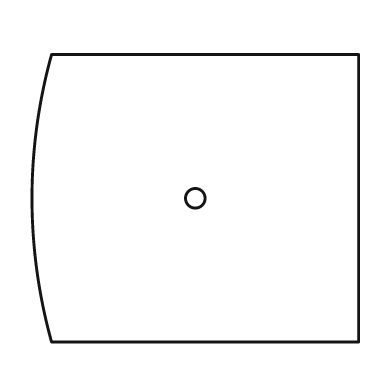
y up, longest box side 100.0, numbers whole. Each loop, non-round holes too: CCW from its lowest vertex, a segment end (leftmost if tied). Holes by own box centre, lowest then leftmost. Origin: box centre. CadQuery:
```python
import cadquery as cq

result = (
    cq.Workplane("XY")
    .moveTo(-44.0, -44.0)
    .lineTo(50.0, -44.0)
    .lineTo(50.0, 44.0)
    .lineTo(-44.0, 44.0)
    .threePointArc((-50.0, 0.0), (-44.0, -44.0))
    .close()
    .moveTo(0.0, 0.0)
    .circle(3.0)
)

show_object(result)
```